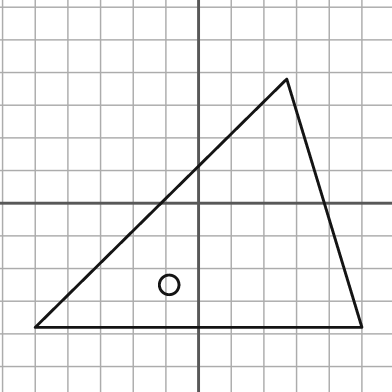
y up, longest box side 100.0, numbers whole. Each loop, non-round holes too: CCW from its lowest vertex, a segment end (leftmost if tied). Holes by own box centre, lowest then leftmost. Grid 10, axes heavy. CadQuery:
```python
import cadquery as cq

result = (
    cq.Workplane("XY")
    .moveTo(-50.0, -38.0)
    .lineTo(50.0, -38.0)
    .lineTo(27.0, 38.0)
    .close()
    .moveTo(-9.0, -25.0)
    .circle(3.0)
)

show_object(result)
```